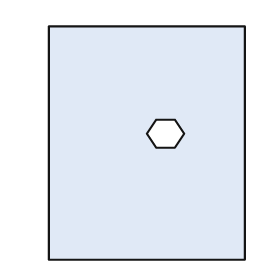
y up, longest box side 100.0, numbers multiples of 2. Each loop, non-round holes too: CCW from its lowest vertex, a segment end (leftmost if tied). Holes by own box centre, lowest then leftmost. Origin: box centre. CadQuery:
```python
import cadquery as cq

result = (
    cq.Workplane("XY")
    .moveTo(-42.0, -50.0)
    .lineTo(42.0, -50.0)
    .lineTo(42.0, 50.0)
    .lineTo(-42.0, 50.0)
    .close()
    .moveTo(4.0, -2.0)
    .lineTo(12.0, -2.0)
    .lineTo(16.0, 4.0)
    .lineTo(12.0, 10.0)
    .lineTo(4.0, 10.0)
    .lineTo(0.0, 4.0)
    .close()
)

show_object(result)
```